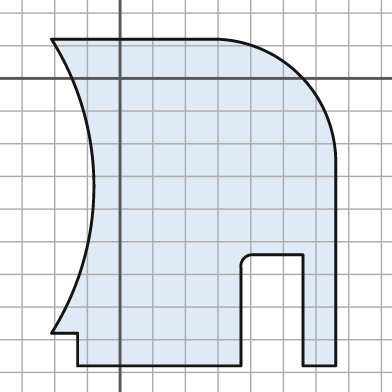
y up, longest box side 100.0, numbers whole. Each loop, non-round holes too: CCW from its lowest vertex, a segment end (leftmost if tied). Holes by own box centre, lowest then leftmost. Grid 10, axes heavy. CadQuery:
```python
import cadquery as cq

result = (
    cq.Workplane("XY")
    .moveTo(-13.0, -88.0)
    .lineTo(37.0, -88.0)
    .lineTo(37.0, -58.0)
    .threePointArc((38.0, -55.0), (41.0, -54.0))
    .lineTo(56.0, -54.0)
    .lineTo(56.0, -88.0)
    .lineTo(66.0, -88.0)
    .lineTo(66.0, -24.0)
    .threePointArc((55.0, 1.0), (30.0, 12.0))
    .lineTo(-21.0, 12.0)
    .threePointArc((-8.0, -33.0), (-21.0, -78.0))
    .lineTo(-13.0, -78.0)
    .close()
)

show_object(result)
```